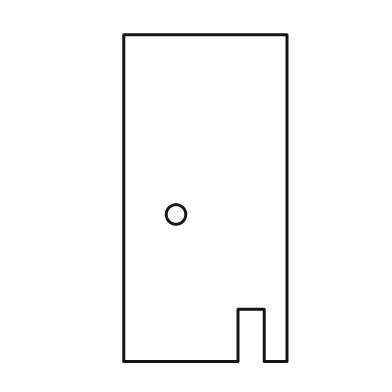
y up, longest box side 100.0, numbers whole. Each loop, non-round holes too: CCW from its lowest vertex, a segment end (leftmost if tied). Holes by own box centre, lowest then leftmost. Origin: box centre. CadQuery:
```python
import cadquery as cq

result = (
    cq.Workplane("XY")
    .moveTo(-25.0, -50.0)
    .lineTo(10.0, -50.0)
    .lineTo(10.0, -34.0)
    .lineTo(18.0, -34.0)
    .lineTo(18.0, -50.0)
    .lineTo(25.0, -50.0)
    .lineTo(25.0, 50.0)
    .lineTo(-25.0, 50.0)
    .close()
    .moveTo(-9.0, -5.0)
    .circle(3.0)
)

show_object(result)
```